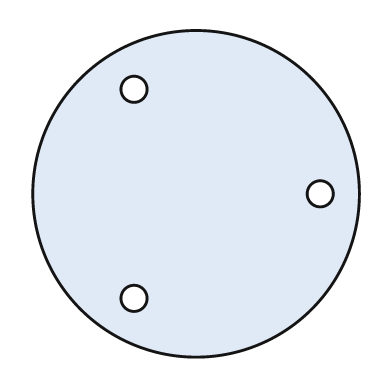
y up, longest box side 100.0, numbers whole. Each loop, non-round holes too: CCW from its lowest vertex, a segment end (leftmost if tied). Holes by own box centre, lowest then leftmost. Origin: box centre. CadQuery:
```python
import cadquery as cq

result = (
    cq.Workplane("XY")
    .moveTo(0.0, 0.0)
    .circle(50.0)
    .moveTo(-19.0, -32.0)
    .circle(4.0)
    .moveTo(38.0, 0.0)
    .circle(4.0)
    .moveTo(-19.0, 32.0)
    .circle(4.0)
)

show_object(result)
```